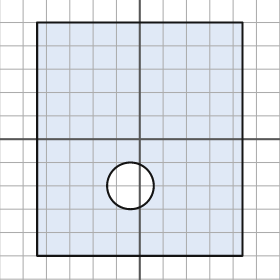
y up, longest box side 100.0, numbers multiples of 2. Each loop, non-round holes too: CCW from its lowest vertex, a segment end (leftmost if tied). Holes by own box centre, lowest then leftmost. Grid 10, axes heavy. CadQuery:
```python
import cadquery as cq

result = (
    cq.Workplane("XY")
    .moveTo(-44.0, -50.0)
    .lineTo(44.0, -50.0)
    .lineTo(44.0, 50.0)
    .lineTo(-44.0, 50.0)
    .close()
    .moveTo(-4.0, -20.0)
    .circle(10.0)
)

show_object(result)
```